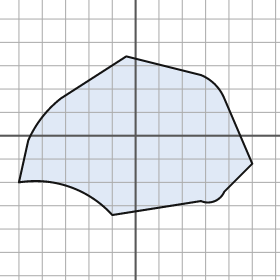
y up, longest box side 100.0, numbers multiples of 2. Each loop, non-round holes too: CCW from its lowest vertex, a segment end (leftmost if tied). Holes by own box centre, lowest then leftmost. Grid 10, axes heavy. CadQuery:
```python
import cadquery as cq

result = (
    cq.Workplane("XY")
    .moveTo(-10.0, -34.0)
    .lineTo(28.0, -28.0)
    .threePointArc((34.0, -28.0), (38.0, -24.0))
    .lineTo(50.0, -12.0)
    .lineTo(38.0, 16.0)
    .threePointArc((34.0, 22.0), (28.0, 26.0))
    .lineTo(-4.0, 34.0)
    .lineTo(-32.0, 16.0)
    .threePointArc((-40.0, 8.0), (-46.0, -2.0))
    .lineTo(-50.0, -20.0)
    .threePointArc((-28.0, -22.0), (-10.0, -34.0))
    .close()
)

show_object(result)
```